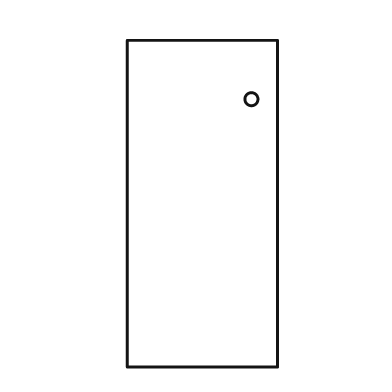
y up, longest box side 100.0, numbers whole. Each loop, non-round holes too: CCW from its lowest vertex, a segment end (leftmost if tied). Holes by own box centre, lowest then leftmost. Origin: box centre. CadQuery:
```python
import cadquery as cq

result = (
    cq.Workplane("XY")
    .moveTo(-23.0, -50.0)
    .lineTo(23.0, -50.0)
    .lineTo(23.0, 50.0)
    .lineTo(-23.0, 50.0)
    .close()
    .moveTo(15.0, 32.0)
    .circle(2.0)
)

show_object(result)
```